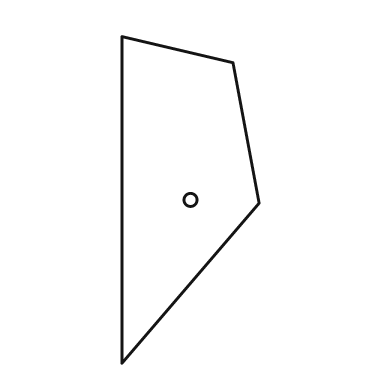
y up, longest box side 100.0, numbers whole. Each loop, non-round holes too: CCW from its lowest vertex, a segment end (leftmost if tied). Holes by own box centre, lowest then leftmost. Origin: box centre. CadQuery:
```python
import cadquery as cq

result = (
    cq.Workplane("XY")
    .moveTo(-21.0, -50.0)
    .lineTo(21.0, -1.0)
    .lineTo(13.0, 42.0)
    .lineTo(-21.0, 50.0)
    .close()
    .moveTo(0.0, 0.0)
    .circle(2.0)
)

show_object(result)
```